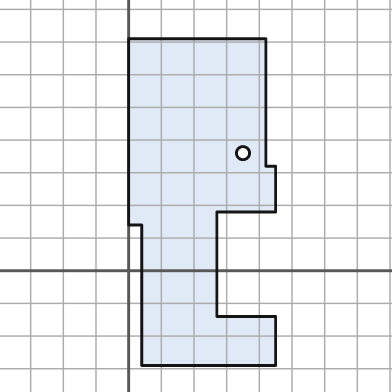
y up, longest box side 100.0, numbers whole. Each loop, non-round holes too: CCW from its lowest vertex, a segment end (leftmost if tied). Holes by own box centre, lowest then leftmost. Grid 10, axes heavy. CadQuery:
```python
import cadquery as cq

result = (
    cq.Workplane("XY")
    .moveTo(4.0, -29.0)
    .lineTo(45.0, -29.0)
    .lineTo(45.0, -14.0)
    .lineTo(27.0, -14.0)
    .lineTo(27.0, 18.0)
    .lineTo(45.0, 18.0)
    .lineTo(45.0, 32.0)
    .lineTo(42.0, 32.0)
    .lineTo(42.0, 71.0)
    .lineTo(0.0, 71.0)
    .lineTo(0.0, 14.0)
    .lineTo(4.0, 14.0)
    .close()
    .moveTo(35.0, 36.0)
    .circle(2.0)
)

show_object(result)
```